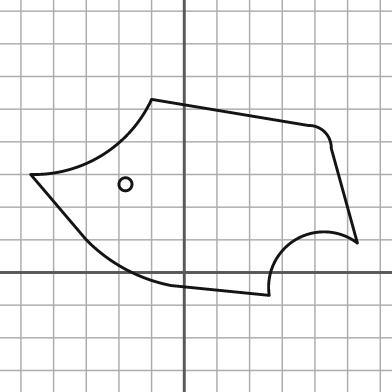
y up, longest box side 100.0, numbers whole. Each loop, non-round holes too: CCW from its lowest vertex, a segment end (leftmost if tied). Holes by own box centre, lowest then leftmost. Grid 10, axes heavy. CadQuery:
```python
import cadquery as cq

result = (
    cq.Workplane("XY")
    .moveTo(26.0, -7.0)
    .threePointArc((34.0, 10.0), (53.0, 9.0))
    .lineTo(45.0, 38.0)
    .threePointArc((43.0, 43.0), (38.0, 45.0))
    .lineTo(-10.0, 53.0)
    .threePointArc((-25.0, 36.0), (-47.0, 30.0))
    .lineTo(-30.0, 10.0)
    .threePointArc((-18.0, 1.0), (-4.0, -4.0))
    .close()
    .moveTo(-18.0, 27.0)
    .circle(2.0)
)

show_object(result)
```